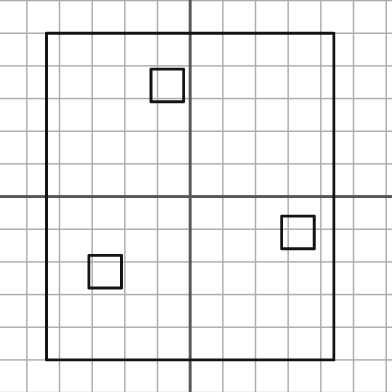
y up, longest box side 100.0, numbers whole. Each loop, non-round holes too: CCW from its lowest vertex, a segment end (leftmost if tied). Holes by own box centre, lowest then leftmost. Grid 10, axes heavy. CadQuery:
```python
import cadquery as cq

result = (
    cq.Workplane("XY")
    .moveTo(-44.0, -50.0)
    .lineTo(44.0, -50.0)
    .lineTo(44.0, 50.0)
    .lineTo(-44.0, 50.0)
    .close()
    .moveTo(-31.0, -28.0)
    .lineTo(-21.0, -28.0)
    .lineTo(-21.0, -18.0)
    .lineTo(-31.0, -18.0)
    .close()
    .moveTo(28.0, -16.0)
    .lineTo(38.0, -16.0)
    .lineTo(38.0, -6.0)
    .lineTo(28.0, -6.0)
    .close()
    .moveTo(-12.0, 29.0)
    .lineTo(-2.0, 29.0)
    .lineTo(-2.0, 39.0)
    .lineTo(-12.0, 39.0)
    .close()
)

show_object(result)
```